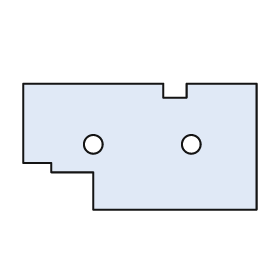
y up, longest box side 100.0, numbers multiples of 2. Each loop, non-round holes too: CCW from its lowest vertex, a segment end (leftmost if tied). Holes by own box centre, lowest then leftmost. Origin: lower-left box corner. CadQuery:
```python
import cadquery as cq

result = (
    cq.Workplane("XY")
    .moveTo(30.0, 0.0)
    .lineTo(100.0, 0.0)
    .lineTo(100.0, 54.0)
    .lineTo(70.0, 54.0)
    .lineTo(70.0, 48.0)
    .lineTo(60.0, 48.0)
    .lineTo(60.0, 54.0)
    .lineTo(0.0, 54.0)
    .lineTo(0.0, 20.0)
    .lineTo(12.0, 20.0)
    .lineTo(12.0, 16.0)
    .lineTo(30.0, 16.0)
    .close()
    .moveTo(30.0, 28.0)
    .circle(4.0)
    .moveTo(72.0, 28.0)
    .circle(4.0)
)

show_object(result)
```